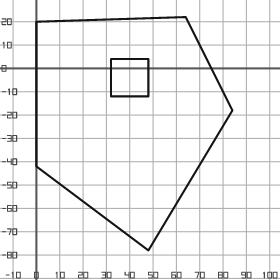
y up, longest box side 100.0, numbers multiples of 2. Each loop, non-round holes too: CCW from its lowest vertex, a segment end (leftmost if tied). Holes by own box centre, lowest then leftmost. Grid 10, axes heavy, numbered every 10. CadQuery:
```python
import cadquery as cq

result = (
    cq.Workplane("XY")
    .moveTo(48.0, -78.0)
    .lineTo(84.0, -18.0)
    .lineTo(64.0, 22.0)
    .lineTo(0.0, 20.0)
    .lineTo(0.0, -42.0)
    .close()
    .moveTo(32.0, -12.0)
    .lineTo(48.0, -12.0)
    .lineTo(48.0, 4.0)
    .lineTo(32.0, 4.0)
    .close()
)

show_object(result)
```